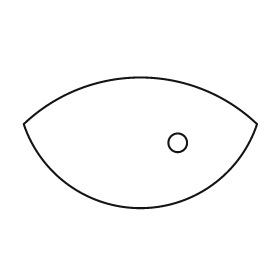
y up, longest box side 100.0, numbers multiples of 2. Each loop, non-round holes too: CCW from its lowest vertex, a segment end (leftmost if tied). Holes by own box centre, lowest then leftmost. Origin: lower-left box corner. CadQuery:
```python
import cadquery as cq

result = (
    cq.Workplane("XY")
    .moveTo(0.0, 36.0)
    .threePointArc((50.0, 0.0), (100.0, 36.0))
    .threePointArc((50.0, 56.0), (0.0, 36.0))
    .close()
    .moveTo(66.0, 28.0)
    .circle(4.0)
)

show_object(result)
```